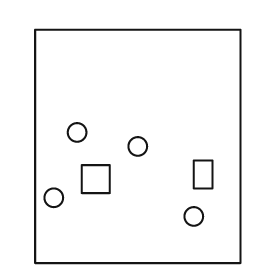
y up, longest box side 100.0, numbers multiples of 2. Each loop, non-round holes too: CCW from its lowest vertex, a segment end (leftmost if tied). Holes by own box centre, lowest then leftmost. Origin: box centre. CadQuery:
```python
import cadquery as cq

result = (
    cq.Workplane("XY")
    .moveTo(-44.0, -50.0)
    .lineTo(44.0, -50.0)
    .lineTo(44.0, 50.0)
    .lineTo(-44.0, 50.0)
    .close()
    .moveTo(24.0, -30.0)
    .circle(4.0)
    .moveTo(-36.0, -22.0)
    .circle(4.0)
    .moveTo(-24.0, -20.0)
    .lineTo(-12.0, -20.0)
    .lineTo(-12.0, -8.0)
    .lineTo(-24.0, -8.0)
    .close()
    .moveTo(24.0, -18.0)
    .lineTo(32.0, -18.0)
    .lineTo(32.0, -6.0)
    .lineTo(24.0, -6.0)
    .close()
    .moveTo(0.0, 0.0)
    .circle(4.0)
    .moveTo(-26.0, 6.0)
    .circle(4.0)
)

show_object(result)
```